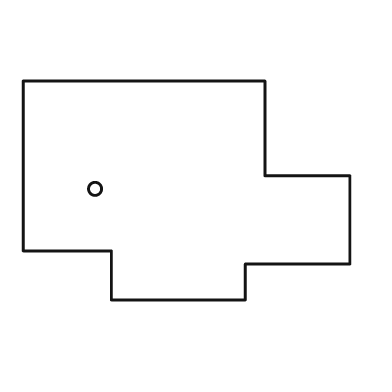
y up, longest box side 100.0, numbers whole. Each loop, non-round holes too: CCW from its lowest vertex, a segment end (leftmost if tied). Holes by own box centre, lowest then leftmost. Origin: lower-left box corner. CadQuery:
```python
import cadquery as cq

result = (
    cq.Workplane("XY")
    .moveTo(27.0, 0.0)
    .lineTo(68.0, 0.0)
    .lineTo(68.0, 11.0)
    .lineTo(100.0, 11.0)
    .lineTo(100.0, 38.0)
    .lineTo(74.0, 38.0)
    .lineTo(74.0, 67.0)
    .lineTo(0.0, 67.0)
    .lineTo(0.0, 15.0)
    .lineTo(27.0, 15.0)
    .close()
    .moveTo(22.0, 34.0)
    .circle(2.0)
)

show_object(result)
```